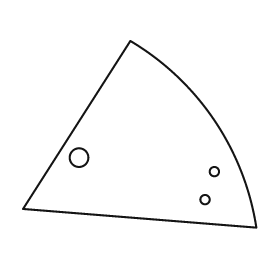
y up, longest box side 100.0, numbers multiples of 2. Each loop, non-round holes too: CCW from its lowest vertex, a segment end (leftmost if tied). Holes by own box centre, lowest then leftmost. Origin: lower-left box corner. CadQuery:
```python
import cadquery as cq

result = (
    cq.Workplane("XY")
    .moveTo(100.0, 0.0)
    .threePointArc((82.0, 46.0), (46.0, 80.0))
    .lineTo(0.0, 8.0)
    .close()
    .moveTo(78.0, 12.0)
    .circle(2.0)
    .moveTo(82.0, 24.0)
    .circle(2.0)
    .moveTo(24.0, 30.0)
    .circle(4.0)
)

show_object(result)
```